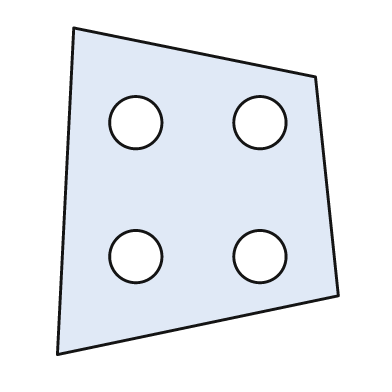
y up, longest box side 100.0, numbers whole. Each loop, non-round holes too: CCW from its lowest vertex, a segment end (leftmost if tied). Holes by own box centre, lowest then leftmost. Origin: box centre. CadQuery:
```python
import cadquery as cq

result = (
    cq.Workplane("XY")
    .moveTo(-43.0, -50.0)
    .lineTo(43.0, -32.0)
    .lineTo(36.0, 35.0)
    .lineTo(-38.0, 50.0)
    .close()
    .moveTo(-19.0, -20.0)
    .circle(8.0)
    .moveTo(19.0, -20.0)
    .circle(8.0)
    .moveTo(-19.0, 21.0)
    .circle(8.0)
    .moveTo(19.0, 21.0)
    .circle(8.0)
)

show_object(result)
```